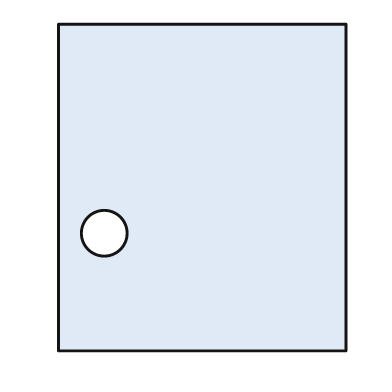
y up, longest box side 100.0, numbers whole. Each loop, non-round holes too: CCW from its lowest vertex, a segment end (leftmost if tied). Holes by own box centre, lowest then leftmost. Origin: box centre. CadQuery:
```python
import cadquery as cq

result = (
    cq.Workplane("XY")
    .moveTo(-44.0, -50.0)
    .lineTo(44.0, -50.0)
    .lineTo(44.0, 50.0)
    .lineTo(-44.0, 50.0)
    .close()
    .moveTo(-30.0, -14.0)
    .circle(7.0)
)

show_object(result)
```